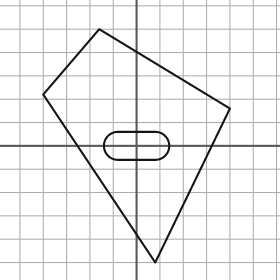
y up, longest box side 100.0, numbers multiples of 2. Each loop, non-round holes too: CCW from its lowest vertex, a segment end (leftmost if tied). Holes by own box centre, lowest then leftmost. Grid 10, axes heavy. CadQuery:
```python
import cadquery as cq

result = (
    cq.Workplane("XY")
    .moveTo(8.0, -50.0)
    .lineTo(40.0, 16.0)
    .lineTo(-16.0, 50.0)
    .lineTo(-40.0, 22.0)
    .close()
    .moveTo(-8.0, -6.0)
    .lineTo(8.0, -6.0)
    .threePointArc((14.0, 0.0), (8.0, 6.0))
    .lineTo(-8.0, 6.0)
    .threePointArc((-14.0, 0.0), (-8.0, -6.0))
    .close()
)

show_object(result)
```